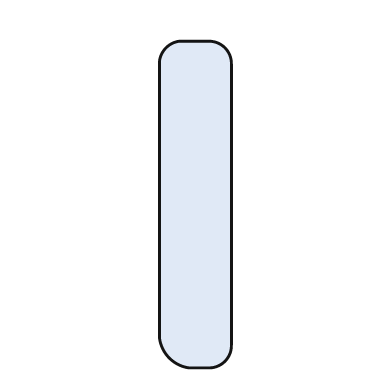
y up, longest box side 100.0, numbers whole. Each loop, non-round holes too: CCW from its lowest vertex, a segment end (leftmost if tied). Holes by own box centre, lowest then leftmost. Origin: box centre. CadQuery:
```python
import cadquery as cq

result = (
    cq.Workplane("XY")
    .moveTo(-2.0, -50.0)
    .lineTo(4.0, -50.0)
    .threePointArc((9.0, -48.0), (11.0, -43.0))
    .lineTo(11.0, 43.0)
    .threePointArc((9.0, 48.0), (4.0, 50.0))
    .lineTo(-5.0, 50.0)
    .threePointArc((-9.0, 48.0), (-11.0, 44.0))
    .lineTo(-11.0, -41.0)
    .threePointArc((-8.0, -47.0), (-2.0, -50.0))
    .close()
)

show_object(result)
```